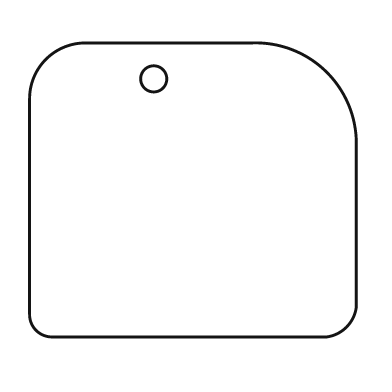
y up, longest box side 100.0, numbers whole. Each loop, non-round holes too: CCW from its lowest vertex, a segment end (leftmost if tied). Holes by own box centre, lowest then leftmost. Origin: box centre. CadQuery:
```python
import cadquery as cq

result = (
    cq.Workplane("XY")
    .moveTo(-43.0, -45.0)
    .lineTo(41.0, -45.0)
    .threePointArc((47.0, -42.0), (50.0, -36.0))
    .lineTo(50.0, 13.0)
    .threePointArc((41.0, 36.0), (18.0, 45.0))
    .lineTo(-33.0, 45.0)
    .threePointArc((-45.0, 40.0), (-50.0, 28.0))
    .lineTo(-50.0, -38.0)
    .threePointArc((-48.0, -43.0), (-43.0, -45.0))
    .close()
    .moveTo(-12.0, 34.0)
    .circle(4.0)
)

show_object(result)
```